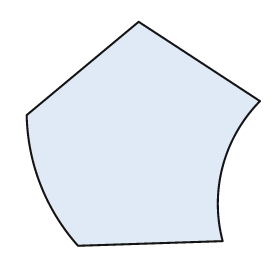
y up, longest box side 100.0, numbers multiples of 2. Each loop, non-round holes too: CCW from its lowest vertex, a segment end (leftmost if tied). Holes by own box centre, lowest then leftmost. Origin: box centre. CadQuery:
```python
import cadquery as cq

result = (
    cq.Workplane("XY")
    .moveTo(-28.0, -48.0)
    .lineTo(34.0, -46.0)
    .threePointArc((34.0, -14.0), (50.0, 14.0))
    .lineTo(-2.0, 48.0)
    .lineTo(-50.0, 8.0)
    .threePointArc((-44.0, -22.0), (-28.0, -48.0))
    .close()
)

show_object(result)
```